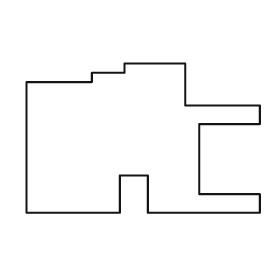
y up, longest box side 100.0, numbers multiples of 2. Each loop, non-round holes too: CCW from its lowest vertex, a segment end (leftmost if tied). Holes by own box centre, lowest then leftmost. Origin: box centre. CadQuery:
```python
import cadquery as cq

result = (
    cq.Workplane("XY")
    .moveTo(-50.0, -32.0)
    .lineTo(-10.0, -32.0)
    .lineTo(-10.0, -16.0)
    .lineTo(2.0, -16.0)
    .lineTo(2.0, -32.0)
    .lineTo(50.0, -32.0)
    .lineTo(50.0, -24.0)
    .lineTo(24.0, -24.0)
    .lineTo(24.0, 6.0)
    .lineTo(50.0, 6.0)
    .lineTo(50.0, 14.0)
    .lineTo(18.0, 14.0)
    .lineTo(18.0, 32.0)
    .lineTo(-8.0, 32.0)
    .lineTo(-8.0, 28.0)
    .lineTo(-22.0, 28.0)
    .lineTo(-22.0, 24.0)
    .lineTo(-50.0, 24.0)
    .close()
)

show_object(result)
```